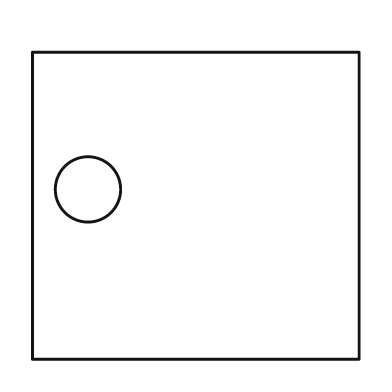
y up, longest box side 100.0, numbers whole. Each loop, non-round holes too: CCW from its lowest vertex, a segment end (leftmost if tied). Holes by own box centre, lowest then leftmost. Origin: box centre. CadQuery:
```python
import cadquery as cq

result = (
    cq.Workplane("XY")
    .moveTo(-50.0, -47.0)
    .lineTo(50.0, -47.0)
    .lineTo(50.0, 47.0)
    .lineTo(-50.0, 47.0)
    .close()
    .moveTo(-33.0, 5.0)
    .circle(10.0)
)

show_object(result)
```